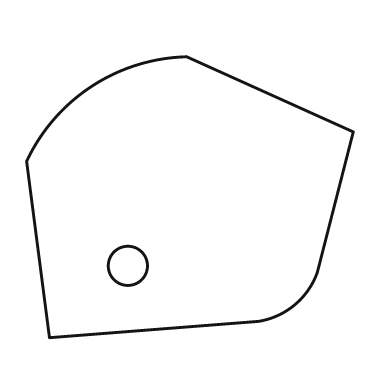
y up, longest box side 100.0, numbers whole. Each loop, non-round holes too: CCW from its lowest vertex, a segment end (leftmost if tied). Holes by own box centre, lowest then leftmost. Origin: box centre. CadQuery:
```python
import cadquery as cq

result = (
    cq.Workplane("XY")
    .moveTo(-43.0, -43.0)
    .lineTo(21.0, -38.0)
    .threePointArc((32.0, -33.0), (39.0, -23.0))
    .lineTo(50.0, 20.0)
    .lineTo(-1.0, 43.0)
    .threePointArc((-30.0, 34.0), (-50.0, 11.0))
    .close()
    .moveTo(-19.0, -21.0)
    .circle(6.0)
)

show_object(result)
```